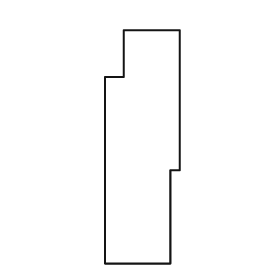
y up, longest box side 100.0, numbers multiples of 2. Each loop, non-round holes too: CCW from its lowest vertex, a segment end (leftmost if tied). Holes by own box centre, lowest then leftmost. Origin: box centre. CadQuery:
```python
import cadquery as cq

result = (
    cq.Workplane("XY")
    .moveTo(-16.0, -50.0)
    .lineTo(12.0, -50.0)
    .lineTo(12.0, -10.0)
    .lineTo(16.0, -10.0)
    .lineTo(16.0, 50.0)
    .lineTo(-8.0, 50.0)
    .lineTo(-8.0, 30.0)
    .lineTo(-16.0, 30.0)
    .close()
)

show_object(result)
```